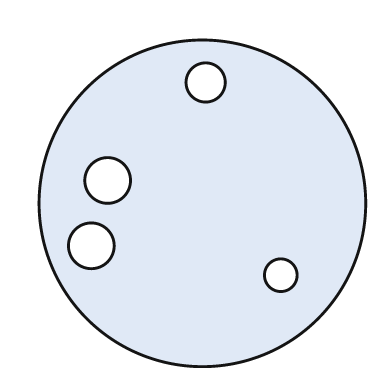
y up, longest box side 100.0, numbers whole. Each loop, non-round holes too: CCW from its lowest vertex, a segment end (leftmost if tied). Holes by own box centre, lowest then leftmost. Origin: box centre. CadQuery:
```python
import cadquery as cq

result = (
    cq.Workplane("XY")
    .moveTo(0.0, 0.0)
    .circle(50.0)
    .moveTo(24.0, -22.0)
    .circle(5.0)
    .moveTo(-34.0, -13.0)
    .circle(7.0)
    .moveTo(-29.0, 7.0)
    .circle(7.0)
    .moveTo(1.0, 37.0)
    .circle(6.0)
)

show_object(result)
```